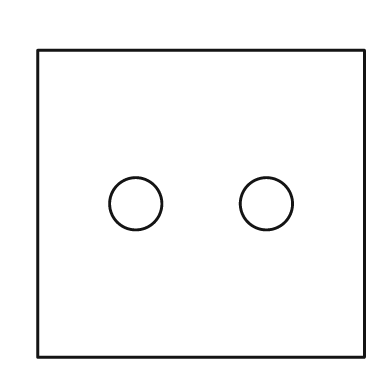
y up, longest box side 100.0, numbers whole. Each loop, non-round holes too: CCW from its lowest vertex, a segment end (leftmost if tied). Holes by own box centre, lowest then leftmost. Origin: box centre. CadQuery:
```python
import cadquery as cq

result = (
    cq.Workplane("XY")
    .moveTo(-50.0, -47.0)
    .lineTo(50.0, -47.0)
    .lineTo(50.0, 47.0)
    .lineTo(-50.0, 47.0)
    .close()
    .moveTo(-20.0, 0.0)
    .circle(8.0)
    .moveTo(20.0, 0.0)
    .circle(8.0)
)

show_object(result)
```